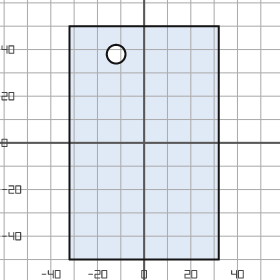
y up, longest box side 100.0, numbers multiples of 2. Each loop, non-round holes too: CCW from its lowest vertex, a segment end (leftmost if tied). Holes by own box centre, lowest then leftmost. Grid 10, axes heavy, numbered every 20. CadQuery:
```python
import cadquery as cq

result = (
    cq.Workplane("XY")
    .moveTo(-32.0, -50.0)
    .lineTo(32.0, -50.0)
    .lineTo(32.0, 50.0)
    .lineTo(-32.0, 50.0)
    .close()
    .moveTo(-12.0, 38.0)
    .circle(4.0)
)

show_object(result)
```